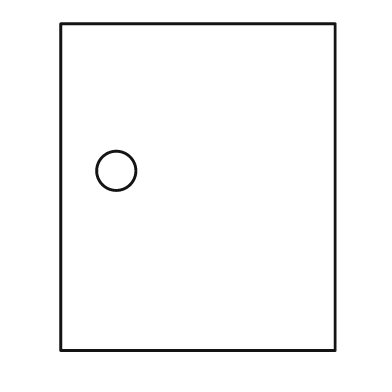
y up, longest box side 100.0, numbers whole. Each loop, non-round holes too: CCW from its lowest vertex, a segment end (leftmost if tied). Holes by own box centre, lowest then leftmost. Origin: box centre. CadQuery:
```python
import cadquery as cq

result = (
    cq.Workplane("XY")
    .moveTo(-42.0, -50.0)
    .lineTo(42.0, -50.0)
    .lineTo(42.0, 50.0)
    .lineTo(-42.0, 50.0)
    .close()
    .moveTo(-25.0, 5.0)
    .circle(6.0)
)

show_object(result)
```